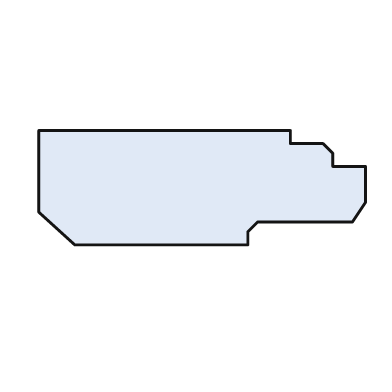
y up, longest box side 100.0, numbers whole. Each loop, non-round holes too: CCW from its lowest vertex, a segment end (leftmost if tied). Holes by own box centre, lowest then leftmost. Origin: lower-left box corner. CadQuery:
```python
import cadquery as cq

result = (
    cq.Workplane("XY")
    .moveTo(11.0, 0.0)
    .lineTo(64.0, 0.0)
    .lineTo(64.0, 4.0)
    .lineTo(67.0, 7.0)
    .lineTo(96.0, 7.0)
    .lineTo(100.0, 13.0)
    .lineTo(100.0, 24.0)
    .lineTo(90.0, 24.0)
    .lineTo(90.0, 28.0)
    .lineTo(87.0, 31.0)
    .lineTo(77.0, 31.0)
    .lineTo(77.0, 35.0)
    .lineTo(0.0, 35.0)
    .lineTo(0.0, 10.0)
    .close()
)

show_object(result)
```